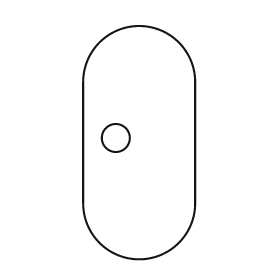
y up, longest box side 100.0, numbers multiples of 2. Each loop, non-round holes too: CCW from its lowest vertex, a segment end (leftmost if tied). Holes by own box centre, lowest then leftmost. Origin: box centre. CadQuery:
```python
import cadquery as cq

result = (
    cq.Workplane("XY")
    .moveTo(-24.0, -26.0)
    .threePointArc((0.0, -50.0), (24.0, -26.0))
    .lineTo(24.0, 26.0)
    .threePointArc((0.0, 50.0), (-24.0, 26.0))
    .close()
    .moveTo(-10.0, 2.0)
    .circle(6.0)
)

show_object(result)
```